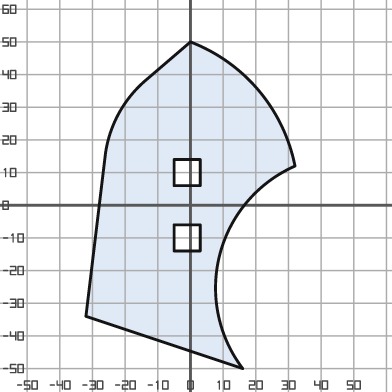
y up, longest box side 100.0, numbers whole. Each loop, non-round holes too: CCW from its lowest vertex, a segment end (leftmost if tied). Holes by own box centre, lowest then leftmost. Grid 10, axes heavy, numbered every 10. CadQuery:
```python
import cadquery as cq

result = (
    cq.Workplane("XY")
    .moveTo(16.0, -50.0)
    .threePointArc((9.0, -15.0), (32.0, 12.0))
    .threePointArc((21.0, 35.0), (0.0, 50.0))
    .lineTo(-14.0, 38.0)
    .threePointArc((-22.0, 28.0), (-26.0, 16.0))
    .lineTo(-32.0, -34.0)
    .close()
    .moveTo(-5.0, -14.0)
    .lineTo(3.0, -14.0)
    .lineTo(3.0, -6.0)
    .lineTo(-5.0, -6.0)
    .close()
    .moveTo(-5.0, 6.0)
    .lineTo(3.0, 6.0)
    .lineTo(3.0, 14.0)
    .lineTo(-5.0, 14.0)
    .close()
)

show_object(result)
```